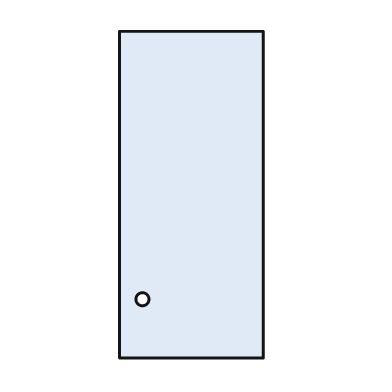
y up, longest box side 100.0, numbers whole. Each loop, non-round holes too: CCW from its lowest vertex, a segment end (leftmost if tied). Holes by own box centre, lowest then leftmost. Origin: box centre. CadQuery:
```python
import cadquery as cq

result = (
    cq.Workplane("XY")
    .moveTo(-22.0, -50.0)
    .lineTo(22.0, -50.0)
    .lineTo(22.0, 50.0)
    .lineTo(-22.0, 50.0)
    .close()
    .moveTo(-15.0, -32.0)
    .circle(2.0)
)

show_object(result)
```